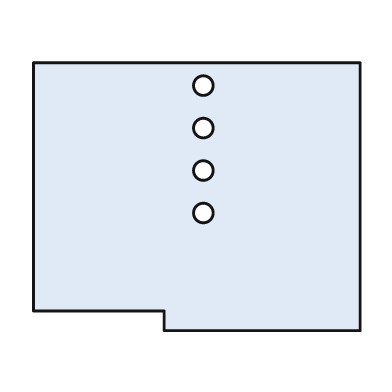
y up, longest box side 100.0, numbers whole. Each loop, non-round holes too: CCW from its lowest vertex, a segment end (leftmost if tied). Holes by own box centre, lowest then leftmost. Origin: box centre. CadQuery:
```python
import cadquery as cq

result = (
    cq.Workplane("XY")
    .moveTo(-10.0, -41.0)
    .lineTo(50.0, -41.0)
    .lineTo(50.0, 41.0)
    .lineTo(-50.0, 41.0)
    .lineTo(-50.0, -35.0)
    .lineTo(-10.0, -35.0)
    .close()
    .moveTo(2.0, -5.0)
    .circle(3.0)
    .moveTo(2.0, 8.0)
    .circle(3.0)
    .moveTo(2.0, 21.0)
    .circle(3.0)
    .moveTo(2.0, 34.0)
    .circle(3.0)
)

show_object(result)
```